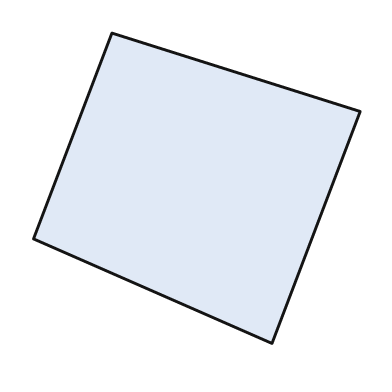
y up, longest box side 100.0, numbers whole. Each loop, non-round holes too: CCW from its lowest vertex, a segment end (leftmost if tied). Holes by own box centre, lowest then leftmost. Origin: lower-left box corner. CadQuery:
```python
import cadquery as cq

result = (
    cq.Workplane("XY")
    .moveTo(73.0, 0.0)
    .lineTo(100.0, 71.0)
    .lineTo(24.0, 95.0)
    .lineTo(0.0, 32.0)
    .close()
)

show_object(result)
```